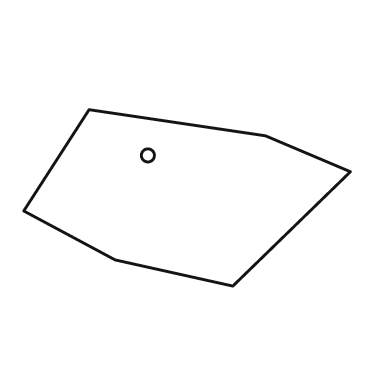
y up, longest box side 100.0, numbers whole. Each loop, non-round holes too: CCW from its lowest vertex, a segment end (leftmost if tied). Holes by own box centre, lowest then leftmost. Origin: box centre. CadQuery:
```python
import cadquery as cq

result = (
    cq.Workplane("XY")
    .moveTo(14.0, -27.0)
    .lineTo(50.0, 8.0)
    .lineTo(24.0, 19.0)
    .lineTo(-30.0, 27.0)
    .lineTo(-50.0, -4.0)
    .lineTo(-22.0, -19.0)
    .close()
    .moveTo(-12.0, 13.0)
    .circle(2.0)
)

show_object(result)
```